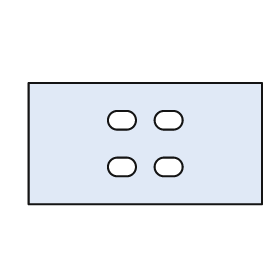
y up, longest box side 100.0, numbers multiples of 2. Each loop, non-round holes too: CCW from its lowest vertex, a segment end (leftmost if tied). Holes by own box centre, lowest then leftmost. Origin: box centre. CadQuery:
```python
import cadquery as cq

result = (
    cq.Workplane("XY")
    .moveTo(-50.0, -26.0)
    .lineTo(50.0, -26.0)
    .lineTo(50.0, 26.0)
    .lineTo(-50.0, 26.0)
    .close()
    .moveTo(-12.0, -14.0)
    .lineTo(-8.0, -14.0)
    .threePointArc((-4.0, -10.0), (-8.0, -6.0))
    .lineTo(-12.0, -6.0)
    .threePointArc((-16.0, -10.0), (-12.0, -14.0))
    .close()
    .moveTo(8.0, -14.0)
    .lineTo(12.0, -14.0)
    .threePointArc((16.0, -10.0), (12.0, -6.0))
    .lineTo(8.0, -6.0)
    .threePointArc((4.0, -10.0), (8.0, -14.0))
    .close()
    .moveTo(-12.0, 6.0)
    .lineTo(-8.0, 6.0)
    .threePointArc((-4.0, 10.0), (-8.0, 14.0))
    .lineTo(-12.0, 14.0)
    .threePointArc((-16.0, 10.0), (-12.0, 6.0))
    .close()
    .moveTo(8.0, 6.0)
    .lineTo(12.0, 6.0)
    .threePointArc((16.0, 10.0), (12.0, 14.0))
    .lineTo(8.0, 14.0)
    .threePointArc((4.0, 10.0), (8.0, 6.0))
    .close()
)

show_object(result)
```